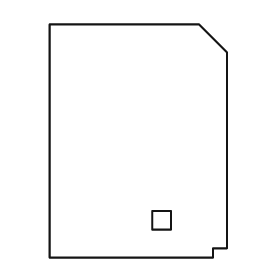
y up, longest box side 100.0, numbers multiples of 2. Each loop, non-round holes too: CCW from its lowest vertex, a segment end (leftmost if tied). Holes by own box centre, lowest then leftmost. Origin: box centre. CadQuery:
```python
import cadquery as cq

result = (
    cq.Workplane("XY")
    .moveTo(-38.0, -50.0)
    .lineTo(32.0, -50.0)
    .lineTo(32.0, -46.0)
    .lineTo(38.0, -46.0)
    .lineTo(38.0, 38.0)
    .lineTo(26.0, 50.0)
    .lineTo(-38.0, 50.0)
    .close()
    .moveTo(6.0, -38.0)
    .lineTo(14.0, -38.0)
    .lineTo(14.0, -30.0)
    .lineTo(6.0, -30.0)
    .close()
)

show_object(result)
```